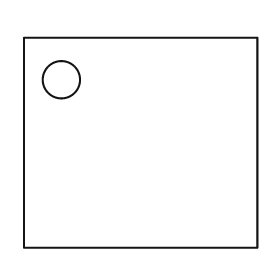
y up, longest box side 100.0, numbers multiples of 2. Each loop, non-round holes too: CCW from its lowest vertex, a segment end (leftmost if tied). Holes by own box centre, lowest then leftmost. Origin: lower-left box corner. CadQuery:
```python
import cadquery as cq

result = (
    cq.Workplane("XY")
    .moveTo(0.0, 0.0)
    .lineTo(100.0, 0.0)
    .lineTo(100.0, 90.0)
    .lineTo(0.0, 90.0)
    .close()
    .moveTo(16.0, 72.0)
    .circle(8.0)
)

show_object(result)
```